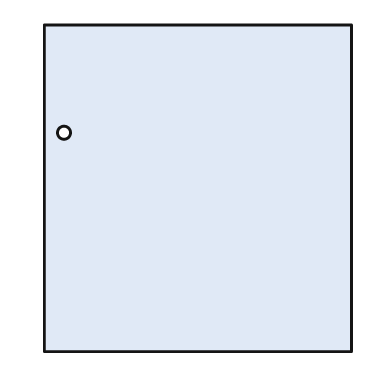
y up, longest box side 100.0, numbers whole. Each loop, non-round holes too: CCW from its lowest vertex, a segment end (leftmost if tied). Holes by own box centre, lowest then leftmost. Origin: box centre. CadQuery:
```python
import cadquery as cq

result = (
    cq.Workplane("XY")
    .moveTo(-47.0, -50.0)
    .lineTo(47.0, -50.0)
    .lineTo(47.0, 50.0)
    .lineTo(-47.0, 50.0)
    .close()
    .moveTo(-41.0, 17.0)
    .circle(2.0)
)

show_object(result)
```